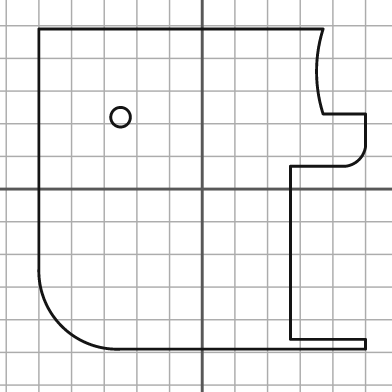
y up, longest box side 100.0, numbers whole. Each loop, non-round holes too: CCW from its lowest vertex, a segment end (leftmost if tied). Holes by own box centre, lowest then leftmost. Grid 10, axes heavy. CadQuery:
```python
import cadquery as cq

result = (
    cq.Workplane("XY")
    .moveTo(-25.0, -49.0)
    .lineTo(50.0, -49.0)
    .lineTo(50.0, -46.0)
    .lineTo(27.0, -46.0)
    .lineTo(27.0, 7.0)
    .lineTo(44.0, 7.0)
    .threePointArc((48.0, 9.0), (50.0, 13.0))
    .lineTo(50.0, 23.0)
    .lineTo(37.0, 23.0)
    .threePointArc((35.0, 36.0), (37.0, 49.0))
    .lineTo(-50.0, 49.0)
    .lineTo(-50.0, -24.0)
    .threePointArc((-43.0, -42.0), (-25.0, -49.0))
    .close()
    .moveTo(-25.0, 22.0)
    .circle(3.0)
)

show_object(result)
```